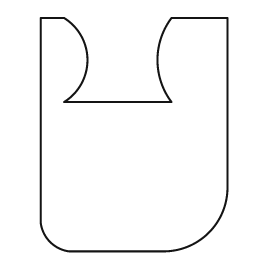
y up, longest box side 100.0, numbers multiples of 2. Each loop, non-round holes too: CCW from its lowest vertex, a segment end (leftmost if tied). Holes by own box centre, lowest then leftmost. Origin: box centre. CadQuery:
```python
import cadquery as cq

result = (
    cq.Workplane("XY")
    .moveTo(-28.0, -50.0)
    .lineTo(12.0, -50.0)
    .threePointArc((32.0, -42.0), (40.0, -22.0))
    .lineTo(40.0, 50.0)
    .lineTo(16.0, 50.0)
    .threePointArc((10.0, 32.0), (16.0, 14.0))
    .lineTo(-30.0, 14.0)
    .threePointArc((-20.0, 32.0), (-30.0, 50.0))
    .lineTo(-40.0, 50.0)
    .lineTo(-40.0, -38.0)
    .threePointArc((-36.0, -46.0), (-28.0, -50.0))
    .close()
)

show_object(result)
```